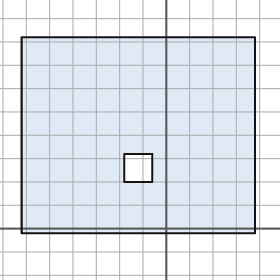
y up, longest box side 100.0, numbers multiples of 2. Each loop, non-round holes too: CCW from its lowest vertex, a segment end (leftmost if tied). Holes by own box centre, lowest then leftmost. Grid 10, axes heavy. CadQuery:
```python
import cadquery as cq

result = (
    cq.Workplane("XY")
    .moveTo(-62.0, -2.0)
    .lineTo(38.0, -2.0)
    .lineTo(38.0, 82.0)
    .lineTo(-62.0, 82.0)
    .close()
    .moveTo(-18.0, 20.0)
    .lineTo(-6.0, 20.0)
    .lineTo(-6.0, 32.0)
    .lineTo(-18.0, 32.0)
    .close()
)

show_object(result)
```